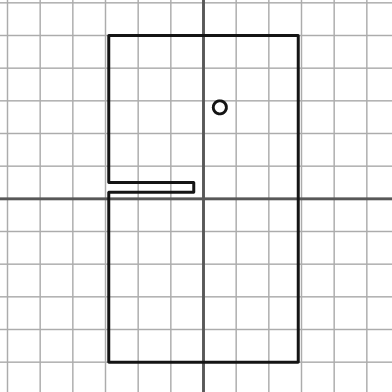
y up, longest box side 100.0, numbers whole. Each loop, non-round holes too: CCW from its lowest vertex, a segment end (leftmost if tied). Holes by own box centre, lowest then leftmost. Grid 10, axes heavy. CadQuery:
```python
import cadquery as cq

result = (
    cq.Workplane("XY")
    .moveTo(-29.0, -50.0)
    .lineTo(29.0, -50.0)
    .lineTo(29.0, 50.0)
    .lineTo(-29.0, 50.0)
    .lineTo(-29.0, 5.0)
    .lineTo(-3.0, 5.0)
    .lineTo(-3.0, 2.0)
    .lineTo(-29.0, 2.0)
    .close()
    .moveTo(5.0, 28.0)
    .circle(2.0)
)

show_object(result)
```